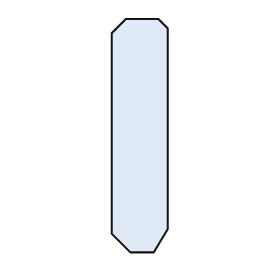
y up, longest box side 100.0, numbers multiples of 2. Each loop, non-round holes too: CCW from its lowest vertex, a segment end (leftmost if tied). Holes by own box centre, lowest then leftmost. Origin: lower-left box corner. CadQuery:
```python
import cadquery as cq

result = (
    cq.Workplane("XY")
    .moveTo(8.0, 0.0)
    .lineTo(18.0, 0.0)
    .lineTo(24.0, 10.0)
    .lineTo(24.0, 96.0)
    .lineTo(20.0, 100.0)
    .lineTo(6.0, 100.0)
    .lineTo(0.0, 94.0)
    .lineTo(0.0, 8.0)
    .close()
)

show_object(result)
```